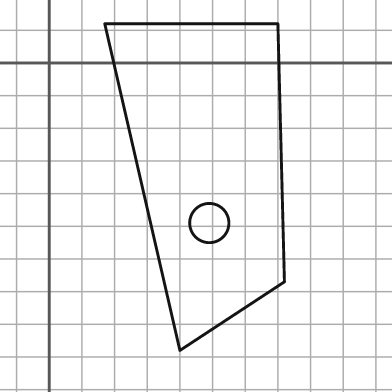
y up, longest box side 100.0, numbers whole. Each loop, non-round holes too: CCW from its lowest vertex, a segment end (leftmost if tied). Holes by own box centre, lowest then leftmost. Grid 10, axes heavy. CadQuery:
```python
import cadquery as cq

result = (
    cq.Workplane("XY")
    .moveTo(40.0, -88.0)
    .lineTo(72.0, -67.0)
    .lineTo(70.0, 12.0)
    .lineTo(17.0, 12.0)
    .close()
    .moveTo(49.0, -49.0)
    .circle(6.0)
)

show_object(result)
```